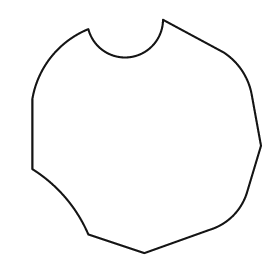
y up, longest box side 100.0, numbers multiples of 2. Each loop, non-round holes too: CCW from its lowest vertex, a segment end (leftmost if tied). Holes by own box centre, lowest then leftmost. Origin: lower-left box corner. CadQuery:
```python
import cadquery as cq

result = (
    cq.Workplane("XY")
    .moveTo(48.0, 0.0)
    .lineTo(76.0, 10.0)
    .threePointArc((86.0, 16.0), (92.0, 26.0))
    .lineTo(98.0, 46.0)
    .lineTo(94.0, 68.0)
    .threePointArc((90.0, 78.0), (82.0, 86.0))
    .lineTo(56.0, 100.0)
    .threePointArc((42.0, 84.0), (24.0, 96.0))
    .threePointArc((8.0, 84.0), (0.0, 66.0))
    .lineTo(0.0, 36.0)
    .threePointArc((14.0, 24.0), (24.0, 8.0))
    .close()
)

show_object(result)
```